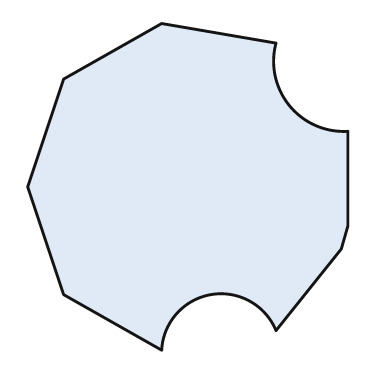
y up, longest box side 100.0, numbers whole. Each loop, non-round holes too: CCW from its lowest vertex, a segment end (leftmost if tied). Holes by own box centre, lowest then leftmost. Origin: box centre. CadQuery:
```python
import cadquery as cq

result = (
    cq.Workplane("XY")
    .moveTo(-8.0, -50.0)
    .threePointArc((7.0, -33.0), (27.0, -44.0))
    .lineTo(47.0, -19.0)
    .lineTo(49.0, -12.0)
    .lineTo(49.0, 17.0)
    .threePointArc((31.0, 25.0), (27.0, 44.0))
    .lineTo(-8.0, 50.0)
    .lineTo(-38.0, 33.0)
    .lineTo(-49.0, 0.0)
    .lineTo(-38.0, -33.0)
    .close()
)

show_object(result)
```